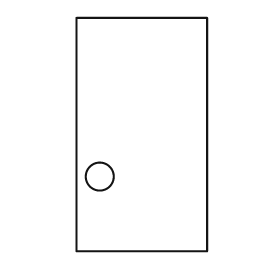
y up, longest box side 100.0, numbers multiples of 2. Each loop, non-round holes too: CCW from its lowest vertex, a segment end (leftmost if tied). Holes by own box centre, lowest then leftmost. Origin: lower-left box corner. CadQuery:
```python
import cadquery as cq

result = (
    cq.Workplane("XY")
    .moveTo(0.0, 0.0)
    .lineTo(56.0, 0.0)
    .lineTo(56.0, 100.0)
    .lineTo(0.0, 100.0)
    .close()
    .moveTo(10.0, 32.0)
    .circle(6.0)
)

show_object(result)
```